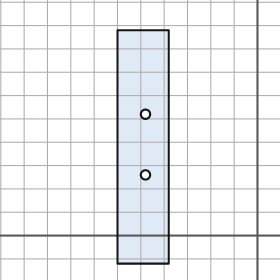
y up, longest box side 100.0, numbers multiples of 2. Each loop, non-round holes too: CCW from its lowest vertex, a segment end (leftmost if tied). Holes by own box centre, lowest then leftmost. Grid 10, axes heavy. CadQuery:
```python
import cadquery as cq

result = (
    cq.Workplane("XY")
    .moveTo(-60.0, -12.0)
    .lineTo(-38.0, -12.0)
    .lineTo(-38.0, 88.0)
    .lineTo(-60.0, 88.0)
    .close()
    .moveTo(-48.0, 26.0)
    .circle(2.0)
    .moveTo(-48.0, 52.0)
    .circle(2.0)
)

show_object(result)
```